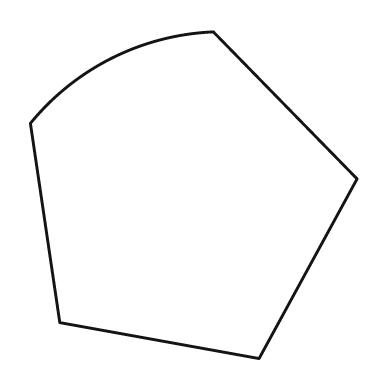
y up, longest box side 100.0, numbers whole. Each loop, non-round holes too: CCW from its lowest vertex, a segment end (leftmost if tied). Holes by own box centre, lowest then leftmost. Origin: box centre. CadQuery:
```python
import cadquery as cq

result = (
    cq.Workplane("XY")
    .moveTo(20.0, -50.0)
    .lineTo(50.0, 5.0)
    .lineTo(6.0, 50.0)
    .threePointArc((-25.0, 42.0), (-50.0, 22.0))
    .lineTo(-41.0, -39.0)
    .close()
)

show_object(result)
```